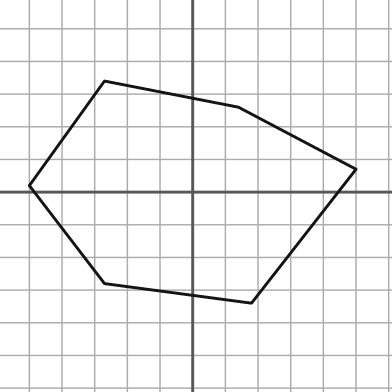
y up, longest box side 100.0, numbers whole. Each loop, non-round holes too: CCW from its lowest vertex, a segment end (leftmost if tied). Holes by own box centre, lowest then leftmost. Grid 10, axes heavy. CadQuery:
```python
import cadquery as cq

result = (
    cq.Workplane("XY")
    .moveTo(18.0, -34.0)
    .lineTo(50.0, 7.0)
    .lineTo(14.0, 26.0)
    .lineTo(-27.0, 34.0)
    .lineTo(-50.0, 2.0)
    .lineTo(-27.0, -28.0)
    .close()
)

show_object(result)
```